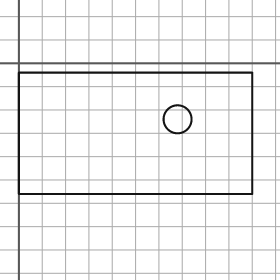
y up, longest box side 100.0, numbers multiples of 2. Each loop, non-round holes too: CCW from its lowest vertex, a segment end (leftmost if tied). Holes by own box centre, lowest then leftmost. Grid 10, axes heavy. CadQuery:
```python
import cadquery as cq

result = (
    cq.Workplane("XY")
    .moveTo(0.0, -56.0)
    .lineTo(100.0, -56.0)
    .lineTo(100.0, -4.0)
    .lineTo(0.0, -4.0)
    .close()
    .moveTo(68.0, -24.0)
    .circle(6.0)
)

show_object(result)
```